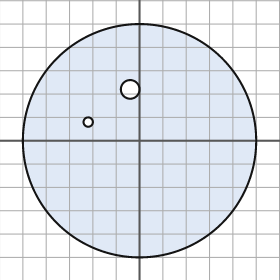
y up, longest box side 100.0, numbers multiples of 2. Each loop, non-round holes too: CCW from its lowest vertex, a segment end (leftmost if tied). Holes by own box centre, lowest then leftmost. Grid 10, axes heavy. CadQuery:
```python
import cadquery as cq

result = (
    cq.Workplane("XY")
    .moveTo(0.0, 0.0)
    .circle(50.0)
    .moveTo(-22.0, 8.0)
    .circle(2.0)
    .moveTo(-4.0, 22.0)
    .circle(4.0)
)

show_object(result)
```